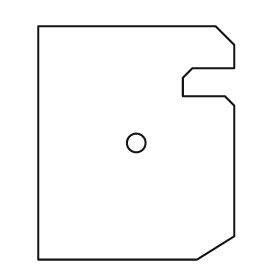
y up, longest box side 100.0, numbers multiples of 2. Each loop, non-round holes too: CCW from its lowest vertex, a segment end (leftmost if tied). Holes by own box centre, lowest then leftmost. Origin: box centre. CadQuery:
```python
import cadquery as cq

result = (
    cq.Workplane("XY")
    .moveTo(-42.0, -50.0)
    .lineTo(26.0, -50.0)
    .lineTo(42.0, -40.0)
    .lineTo(42.0, 16.0)
    .lineTo(38.0, 20.0)
    .lineTo(20.0, 20.0)
    .lineTo(20.0, 28.0)
    .lineTo(24.0, 32.0)
    .lineTo(42.0, 32.0)
    .lineTo(42.0, 42.0)
    .lineTo(34.0, 50.0)
    .lineTo(-42.0, 50.0)
    .close()
    .moveTo(0.0, 0.0)
    .circle(4.0)
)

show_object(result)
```